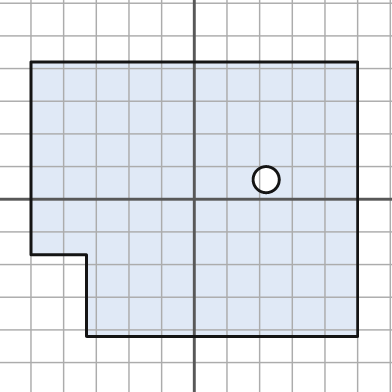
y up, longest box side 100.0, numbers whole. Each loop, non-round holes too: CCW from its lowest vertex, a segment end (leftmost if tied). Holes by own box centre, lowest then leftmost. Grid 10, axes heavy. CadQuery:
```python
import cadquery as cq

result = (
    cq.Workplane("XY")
    .moveTo(-33.0, -42.0)
    .lineTo(50.0, -42.0)
    .lineTo(50.0, 42.0)
    .lineTo(-50.0, 42.0)
    .lineTo(-50.0, -17.0)
    .lineTo(-33.0, -17.0)
    .close()
    .moveTo(22.0, 6.0)
    .circle(4.0)
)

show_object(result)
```